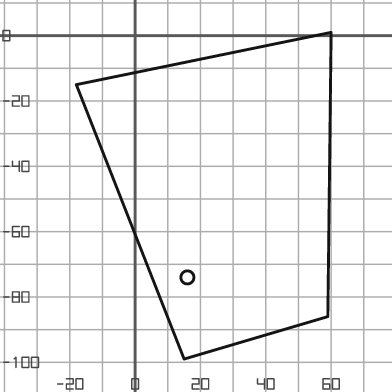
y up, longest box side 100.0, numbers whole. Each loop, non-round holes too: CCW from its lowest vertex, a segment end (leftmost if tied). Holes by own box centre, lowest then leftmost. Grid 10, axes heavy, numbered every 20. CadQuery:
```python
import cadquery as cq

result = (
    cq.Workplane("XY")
    .moveTo(15.0, -99.0)
    .lineTo(59.0, -86.0)
    .lineTo(60.0, 1.0)
    .lineTo(-18.0, -15.0)
    .close()
    .moveTo(16.0, -74.0)
    .circle(2.0)
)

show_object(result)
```